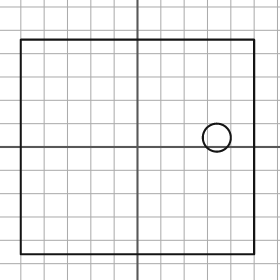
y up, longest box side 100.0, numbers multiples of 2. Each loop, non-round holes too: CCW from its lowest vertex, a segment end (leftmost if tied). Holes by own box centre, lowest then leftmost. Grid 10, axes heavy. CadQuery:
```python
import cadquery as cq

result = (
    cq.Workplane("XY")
    .moveTo(-50.0, -46.0)
    .lineTo(50.0, -46.0)
    .lineTo(50.0, 46.0)
    .lineTo(-50.0, 46.0)
    .close()
    .moveTo(34.0, 4.0)
    .circle(6.0)
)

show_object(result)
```